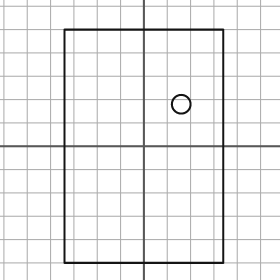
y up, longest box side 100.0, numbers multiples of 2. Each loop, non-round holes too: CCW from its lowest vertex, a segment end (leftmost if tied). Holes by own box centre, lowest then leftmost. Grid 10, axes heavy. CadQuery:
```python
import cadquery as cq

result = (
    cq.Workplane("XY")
    .moveTo(-34.0, -50.0)
    .lineTo(34.0, -50.0)
    .lineTo(34.0, 50.0)
    .lineTo(-34.0, 50.0)
    .close()
    .moveTo(16.0, 18.0)
    .circle(4.0)
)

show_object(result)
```